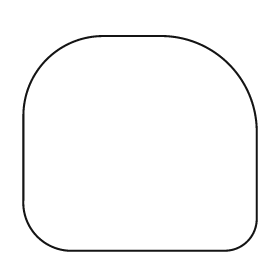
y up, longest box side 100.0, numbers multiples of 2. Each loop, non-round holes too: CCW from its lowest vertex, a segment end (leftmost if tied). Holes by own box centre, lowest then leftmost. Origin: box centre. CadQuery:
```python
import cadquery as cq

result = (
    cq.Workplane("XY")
    .moveTo(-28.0, -46.0)
    .lineTo(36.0, -46.0)
    .threePointArc((46.0, -42.0), (50.0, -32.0))
    .lineTo(50.0, 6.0)
    .threePointArc((38.0, 34.0), (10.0, 46.0))
    .lineTo(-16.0, 46.0)
    .threePointArc((-40.0, 36.0), (-50.0, 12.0))
    .lineTo(-50.0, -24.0)
    .threePointArc((-44.0, -40.0), (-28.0, -46.0))
    .close()
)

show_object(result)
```